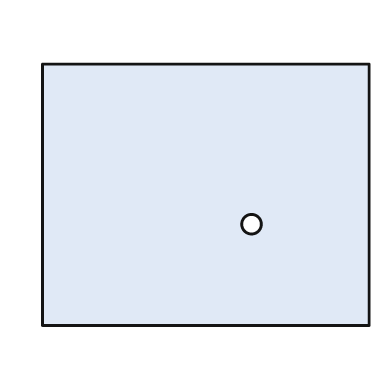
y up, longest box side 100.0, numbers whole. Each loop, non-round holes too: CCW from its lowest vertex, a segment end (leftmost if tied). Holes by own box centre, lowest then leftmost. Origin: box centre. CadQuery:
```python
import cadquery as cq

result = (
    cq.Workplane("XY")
    .moveTo(-50.0, -40.0)
    .lineTo(50.0, -40.0)
    .lineTo(50.0, 40.0)
    .lineTo(-50.0, 40.0)
    .close()
    .moveTo(14.0, -9.0)
    .circle(3.0)
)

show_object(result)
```